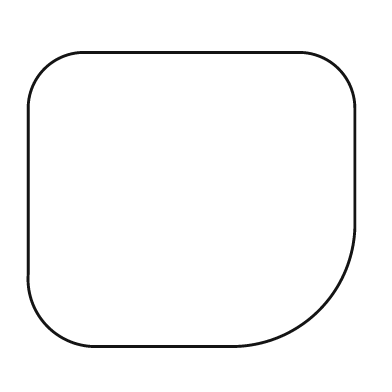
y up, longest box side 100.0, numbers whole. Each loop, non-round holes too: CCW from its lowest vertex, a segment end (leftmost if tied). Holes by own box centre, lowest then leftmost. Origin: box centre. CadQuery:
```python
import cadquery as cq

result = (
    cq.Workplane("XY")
    .moveTo(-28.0, -45.0)
    .lineTo(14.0, -45.0)
    .threePointArc((39.0, -34.0), (50.0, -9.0))
    .lineTo(50.0, 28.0)
    .threePointArc((45.0, 40.0), (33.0, 45.0))
    .lineTo(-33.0, 45.0)
    .threePointArc((-45.0, 40.0), (-50.0, 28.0))
    .lineTo(-50.0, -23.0)
    .threePointArc((-44.0, -39.0), (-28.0, -45.0))
    .close()
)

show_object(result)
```